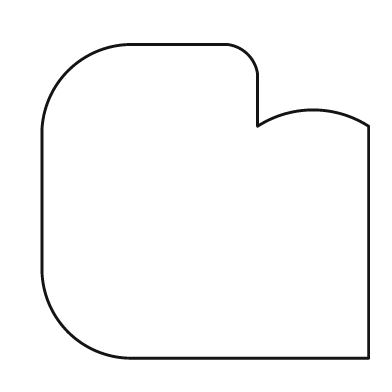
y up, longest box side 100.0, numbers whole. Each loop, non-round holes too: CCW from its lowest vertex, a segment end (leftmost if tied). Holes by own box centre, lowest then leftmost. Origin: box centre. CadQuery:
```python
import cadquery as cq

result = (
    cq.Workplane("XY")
    .moveTo(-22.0, -48.0)
    .lineTo(50.0, -48.0)
    .lineTo(50.0, 23.0)
    .threePointArc((33.0, 28.0), (16.0, 23.0))
    .lineTo(16.0, 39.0)
    .threePointArc((13.0, 45.0), (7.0, 48.0))
    .lineTo(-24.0, 48.0)
    .threePointArc((-42.0, 40.0), (-50.0, 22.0))
    .lineTo(-50.0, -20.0)
    .threePointArc((-42.0, -40.0), (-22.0, -48.0))
    .close()
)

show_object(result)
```